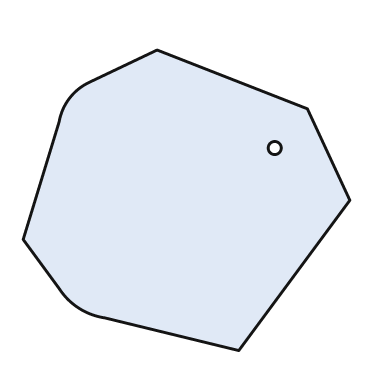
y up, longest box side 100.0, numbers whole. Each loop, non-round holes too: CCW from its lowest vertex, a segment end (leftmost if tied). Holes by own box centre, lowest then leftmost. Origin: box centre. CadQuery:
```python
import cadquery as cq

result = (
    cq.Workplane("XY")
    .moveTo(16.0, -46.0)
    .lineTo(50.0, 0.0)
    .lineTo(37.0, 28.0)
    .lineTo(-9.0, 46.0)
    .lineTo(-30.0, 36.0)
    .threePointArc((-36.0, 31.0), (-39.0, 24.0))
    .lineTo(-50.0, -12.0)
    .lineTo(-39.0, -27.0)
    .threePointArc((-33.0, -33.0), (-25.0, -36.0))
    .close()
    .moveTo(27.0, 16.0)
    .circle(2.0)
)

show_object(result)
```